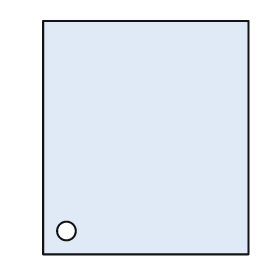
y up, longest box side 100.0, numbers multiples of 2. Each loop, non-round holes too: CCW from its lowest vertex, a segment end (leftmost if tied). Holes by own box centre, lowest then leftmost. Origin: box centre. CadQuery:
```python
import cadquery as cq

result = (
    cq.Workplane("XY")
    .moveTo(-44.0, -50.0)
    .lineTo(44.0, -50.0)
    .lineTo(44.0, 50.0)
    .lineTo(-44.0, 50.0)
    .close()
    .moveTo(-34.0, -40.0)
    .circle(4.0)
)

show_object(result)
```